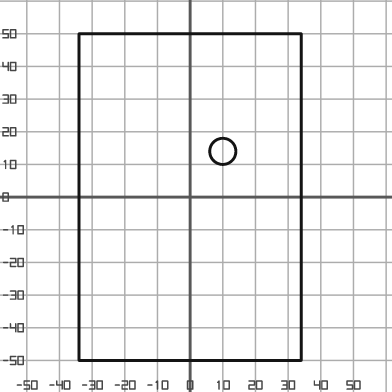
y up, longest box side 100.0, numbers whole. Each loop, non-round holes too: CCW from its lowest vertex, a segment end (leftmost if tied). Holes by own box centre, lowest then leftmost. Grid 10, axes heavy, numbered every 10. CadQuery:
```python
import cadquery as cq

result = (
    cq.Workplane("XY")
    .moveTo(-34.0, -50.0)
    .lineTo(34.0, -50.0)
    .lineTo(34.0, 50.0)
    .lineTo(-34.0, 50.0)
    .close()
    .moveTo(10.0, 14.0)
    .circle(4.0)
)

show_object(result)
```